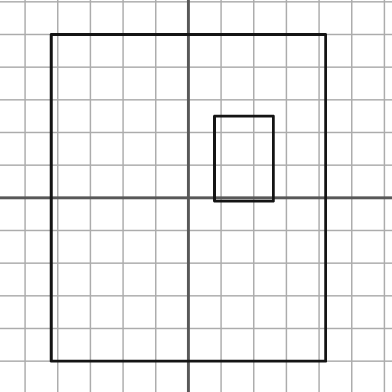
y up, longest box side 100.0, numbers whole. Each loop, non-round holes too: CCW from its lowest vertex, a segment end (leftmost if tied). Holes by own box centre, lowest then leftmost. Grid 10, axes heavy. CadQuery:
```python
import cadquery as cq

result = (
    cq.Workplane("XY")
    .moveTo(-42.0, -50.0)
    .lineTo(42.0, -50.0)
    .lineTo(42.0, 50.0)
    .lineTo(-42.0, 50.0)
    .close()
    .moveTo(8.0, -1.0)
    .lineTo(26.0, -1.0)
    .lineTo(26.0, 25.0)
    .lineTo(8.0, 25.0)
    .close()
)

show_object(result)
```